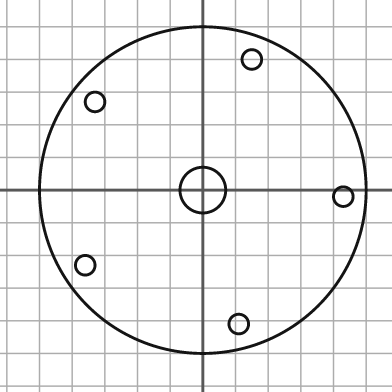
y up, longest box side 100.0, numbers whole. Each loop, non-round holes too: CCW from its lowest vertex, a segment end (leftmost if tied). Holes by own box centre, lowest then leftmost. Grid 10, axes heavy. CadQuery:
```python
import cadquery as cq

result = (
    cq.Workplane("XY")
    .moveTo(0.0, 0.0)
    .circle(50.0)
    .moveTo(11.0, -41.0)
    .circle(3.0)
    .moveTo(-36.0, -23.0)
    .circle(3.0)
    .moveTo(43.0, -2.0)
    .circle(3.0)
    .moveTo(0.0, 0.0)
    .circle(7.0)
    .moveTo(-33.0, 27.0)
    .circle(3.0)
    .moveTo(15.0, 40.0)
    .circle(3.0)
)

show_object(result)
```